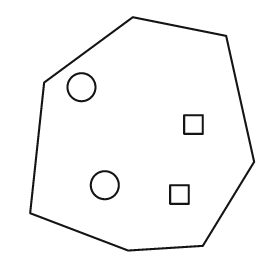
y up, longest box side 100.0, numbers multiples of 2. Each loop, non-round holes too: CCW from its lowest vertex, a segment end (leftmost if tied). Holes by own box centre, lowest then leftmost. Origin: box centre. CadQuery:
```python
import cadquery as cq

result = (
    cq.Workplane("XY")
    .moveTo(-6.0, -50.0)
    .lineTo(26.0, -48.0)
    .lineTo(48.0, -12.0)
    .lineTo(36.0, 42.0)
    .lineTo(-4.0, 50.0)
    .lineTo(-42.0, 22.0)
    .lineTo(-48.0, -34.0)
    .close()
    .moveTo(12.0, -30.0)
    .lineTo(20.0, -30.0)
    .lineTo(20.0, -22.0)
    .lineTo(12.0, -22.0)
    .close()
    .moveTo(-16.0, -22.0)
    .circle(6.0)
    .moveTo(18.0, 0.0)
    .lineTo(26.0, 0.0)
    .lineTo(26.0, 8.0)
    .lineTo(18.0, 8.0)
    .close()
    .moveTo(-26.0, 20.0)
    .circle(6.0)
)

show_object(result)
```